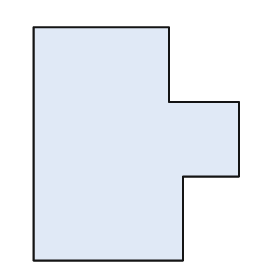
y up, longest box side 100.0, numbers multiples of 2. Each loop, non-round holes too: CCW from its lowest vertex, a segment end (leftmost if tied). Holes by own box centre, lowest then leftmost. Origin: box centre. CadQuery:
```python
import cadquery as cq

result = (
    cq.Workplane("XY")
    .moveTo(-44.0, -50.0)
    .lineTo(20.0, -50.0)
    .lineTo(20.0, -14.0)
    .lineTo(44.0, -14.0)
    .lineTo(44.0, 18.0)
    .lineTo(14.0, 18.0)
    .lineTo(14.0, 50.0)
    .lineTo(-44.0, 50.0)
    .close()
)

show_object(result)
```